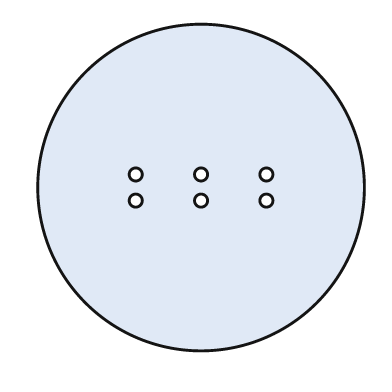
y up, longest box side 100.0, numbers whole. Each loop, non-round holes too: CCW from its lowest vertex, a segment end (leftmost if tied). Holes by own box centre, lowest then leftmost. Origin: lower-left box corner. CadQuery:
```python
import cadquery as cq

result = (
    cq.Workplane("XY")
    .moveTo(50.0, 50.0)
    .circle(50.0)
    .moveTo(30.0, 46.0)
    .circle(2.0)
    .moveTo(50.0, 46.0)
    .circle(2.0)
    .moveTo(70.0, 46.0)
    .circle(2.0)
    .moveTo(30.0, 54.0)
    .circle(2.0)
    .moveTo(50.0, 54.0)
    .circle(2.0)
    .moveTo(70.0, 54.0)
    .circle(2.0)
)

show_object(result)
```